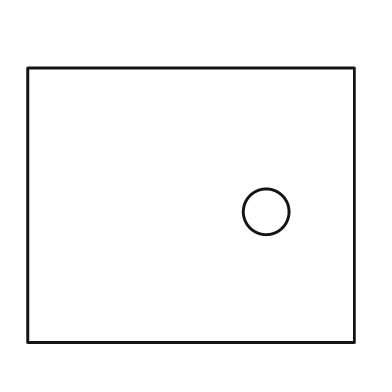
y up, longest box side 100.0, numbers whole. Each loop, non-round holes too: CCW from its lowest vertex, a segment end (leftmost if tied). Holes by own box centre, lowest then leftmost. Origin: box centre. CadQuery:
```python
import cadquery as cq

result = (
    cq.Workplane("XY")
    .moveTo(-50.0, -42.0)
    .lineTo(50.0, -42.0)
    .lineTo(50.0, 42.0)
    .lineTo(-50.0, 42.0)
    .close()
    .moveTo(23.0, -2.0)
    .circle(7.0)
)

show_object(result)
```